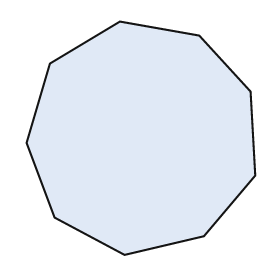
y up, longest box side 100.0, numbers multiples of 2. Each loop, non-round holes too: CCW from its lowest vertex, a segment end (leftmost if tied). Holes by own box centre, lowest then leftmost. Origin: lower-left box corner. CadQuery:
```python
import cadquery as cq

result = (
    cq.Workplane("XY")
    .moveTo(42.0, 0.0)
    .lineTo(76.0, 8.0)
    .lineTo(98.0, 34.0)
    .lineTo(96.0, 70.0)
    .lineTo(74.0, 94.0)
    .lineTo(40.0, 100.0)
    .lineTo(10.0, 82.0)
    .lineTo(0.0, 48.0)
    .lineTo(12.0, 16.0)
    .close()
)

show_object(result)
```